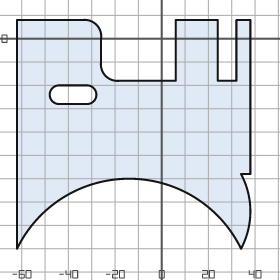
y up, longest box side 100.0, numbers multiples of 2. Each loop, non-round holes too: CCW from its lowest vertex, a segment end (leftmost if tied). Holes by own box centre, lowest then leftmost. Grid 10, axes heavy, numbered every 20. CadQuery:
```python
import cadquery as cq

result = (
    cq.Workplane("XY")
    .moveTo(-62.0, -90.0)
    .threePointArc((-14.0, -60.0), (34.0, -90.0))
    .threePointArc((38.0, -74.0), (34.0, -58.0))
    .lineTo(38.0, -58.0)
    .lineTo(38.0, 8.0)
    .lineTo(32.0, 8.0)
    .lineTo(32.0, -18.0)
    .lineTo(24.0, -18.0)
    .lineTo(24.0, 8.0)
    .lineTo(6.0, 8.0)
    .lineTo(6.0, -18.0)
    .lineTo(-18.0, -18.0)
    .threePointArc((-24.0, -16.0), (-26.0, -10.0))
    .lineTo(-26.0, 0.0)
    .threePointArc((-28.0, 6.0), (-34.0, 8.0))
    .lineTo(-62.0, 8.0)
    .close()
    .moveTo(-44.0, -28.0)
    .lineTo(-32.0, -28.0)
    .threePointArc((-28.0, -24.0), (-32.0, -20.0))
    .lineTo(-44.0, -20.0)
    .threePointArc((-48.0, -24.0), (-44.0, -28.0))
    .close()
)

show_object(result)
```